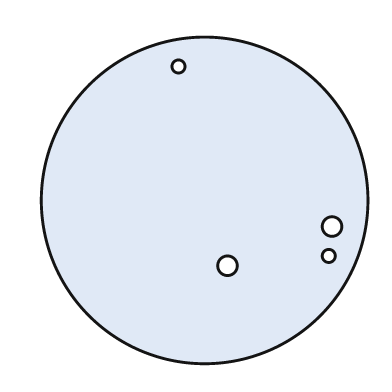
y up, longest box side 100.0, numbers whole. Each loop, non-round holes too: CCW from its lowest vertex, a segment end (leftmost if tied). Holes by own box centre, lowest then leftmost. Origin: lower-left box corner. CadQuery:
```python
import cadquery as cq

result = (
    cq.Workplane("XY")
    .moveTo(50.0, 50.0)
    .circle(50.0)
    .moveTo(57.0, 30.0)
    .circle(3.0)
    .moveTo(88.0, 33.0)
    .circle(2.0)
    .moveTo(89.0, 42.0)
    .circle(3.0)
    .moveTo(42.0, 91.0)
    .circle(2.0)
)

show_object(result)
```